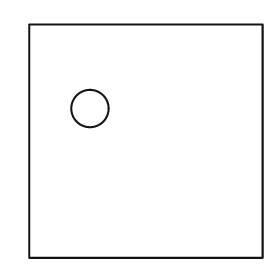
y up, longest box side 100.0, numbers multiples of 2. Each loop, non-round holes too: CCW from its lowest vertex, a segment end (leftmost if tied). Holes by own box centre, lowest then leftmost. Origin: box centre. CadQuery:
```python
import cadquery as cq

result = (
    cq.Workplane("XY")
    .moveTo(-50.0, -50.0)
    .lineTo(50.0, -50.0)
    .lineTo(50.0, 50.0)
    .lineTo(-50.0, 50.0)
    .close()
    .moveTo(-24.0, 14.0)
    .circle(8.0)
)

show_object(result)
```